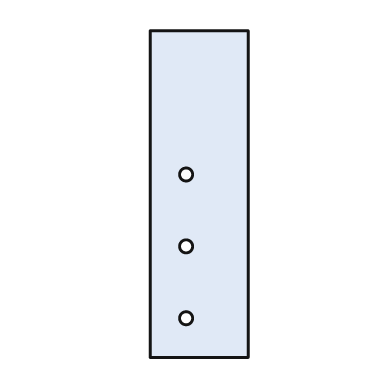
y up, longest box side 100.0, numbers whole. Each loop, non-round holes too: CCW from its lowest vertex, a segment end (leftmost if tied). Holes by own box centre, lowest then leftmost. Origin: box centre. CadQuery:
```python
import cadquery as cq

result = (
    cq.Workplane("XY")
    .moveTo(-15.0, -50.0)
    .lineTo(15.0, -50.0)
    .lineTo(15.0, 50.0)
    .lineTo(-15.0, 50.0)
    .close()
    .moveTo(-4.0, -38.0)
    .circle(2.0)
    .moveTo(-4.0, -16.0)
    .circle(2.0)
    .moveTo(-4.0, 6.0)
    .circle(2.0)
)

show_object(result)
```